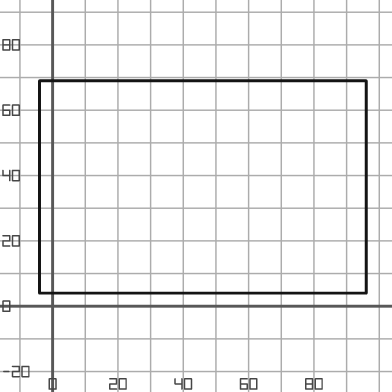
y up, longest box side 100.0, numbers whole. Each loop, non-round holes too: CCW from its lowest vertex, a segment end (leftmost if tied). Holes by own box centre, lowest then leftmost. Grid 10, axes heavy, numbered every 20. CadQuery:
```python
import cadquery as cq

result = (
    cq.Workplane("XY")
    .moveTo(-4.0, 4.0)
    .lineTo(96.0, 4.0)
    .lineTo(96.0, 69.0)
    .lineTo(-4.0, 69.0)
    .close()
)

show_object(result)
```